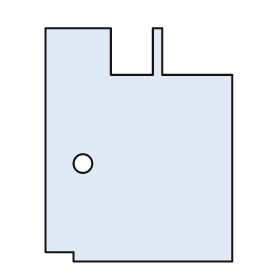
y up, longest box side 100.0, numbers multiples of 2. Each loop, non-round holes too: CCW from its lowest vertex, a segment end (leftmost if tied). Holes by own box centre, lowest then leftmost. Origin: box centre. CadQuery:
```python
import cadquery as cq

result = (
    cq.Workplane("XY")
    .moveTo(-28.0, -50.0)
    .lineTo(40.0, -50.0)
    .lineTo(40.0, 30.0)
    .lineTo(10.0, 30.0)
    .lineTo(10.0, 50.0)
    .lineTo(6.0, 50.0)
    .lineTo(6.0, 30.0)
    .lineTo(-12.0, 30.0)
    .lineTo(-12.0, 50.0)
    .lineTo(-40.0, 50.0)
    .lineTo(-40.0, -46.0)
    .lineTo(-28.0, -46.0)
    .close()
    .moveTo(-24.0, -8.0)
    .circle(4.0)
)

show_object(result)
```